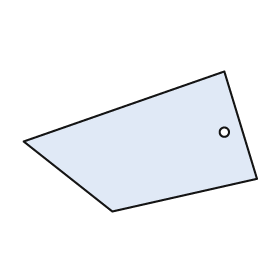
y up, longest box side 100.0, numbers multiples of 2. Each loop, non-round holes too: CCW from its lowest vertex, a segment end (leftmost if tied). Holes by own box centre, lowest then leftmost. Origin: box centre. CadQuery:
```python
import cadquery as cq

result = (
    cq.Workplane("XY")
    .moveTo(-12.0, -30.0)
    .lineTo(50.0, -16.0)
    .lineTo(36.0, 30.0)
    .lineTo(-50.0, 0.0)
    .close()
    .moveTo(36.0, 4.0)
    .circle(2.0)
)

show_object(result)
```